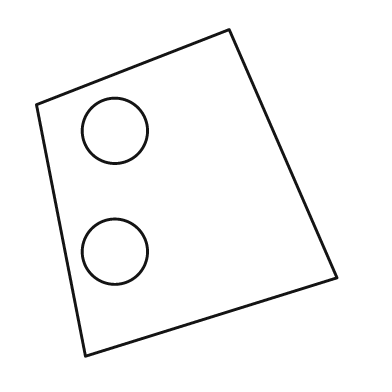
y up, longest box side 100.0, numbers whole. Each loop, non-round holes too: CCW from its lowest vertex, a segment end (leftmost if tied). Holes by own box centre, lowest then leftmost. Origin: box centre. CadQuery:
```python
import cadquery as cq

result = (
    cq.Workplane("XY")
    .moveTo(-31.0, -50.0)
    .lineTo(46.0, -26.0)
    .lineTo(13.0, 50.0)
    .lineTo(-46.0, 27.0)
    .close()
    .moveTo(-22.0, -18.0)
    .circle(10.0)
    .moveTo(-22.0, 19.0)
    .circle(10.0)
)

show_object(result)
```